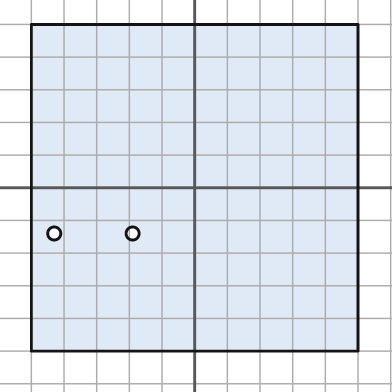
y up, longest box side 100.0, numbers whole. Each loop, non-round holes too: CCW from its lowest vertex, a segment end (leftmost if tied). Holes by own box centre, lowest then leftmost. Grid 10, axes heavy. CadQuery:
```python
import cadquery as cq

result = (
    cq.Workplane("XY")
    .moveTo(-50.0, -50.0)
    .lineTo(50.0, -50.0)
    .lineTo(50.0, 50.0)
    .lineTo(-50.0, 50.0)
    .close()
    .moveTo(-43.0, -14.0)
    .circle(2.0)
    .moveTo(-19.0, -14.0)
    .circle(2.0)
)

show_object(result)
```